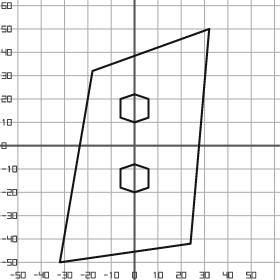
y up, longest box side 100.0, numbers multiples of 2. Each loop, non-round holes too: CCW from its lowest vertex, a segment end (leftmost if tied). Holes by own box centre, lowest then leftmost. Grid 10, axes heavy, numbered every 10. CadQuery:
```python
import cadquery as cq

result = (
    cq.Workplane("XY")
    .moveTo(-32.0, -50.0)
    .lineTo(24.0, -42.0)
    .lineTo(32.0, 50.0)
    .lineTo(-18.0, 32.0)
    .close()
    .moveTo(0.0, -20.0)
    .lineTo(6.0, -18.0)
    .lineTo(6.0, -10.0)
    .lineTo(0.0, -8.0)
    .lineTo(-6.0, -10.0)
    .lineTo(-6.0, -18.0)
    .close()
    .moveTo(0.0, 10.0)
    .lineTo(6.0, 12.0)
    .lineTo(6.0, 20.0)
    .lineTo(0.0, 22.0)
    .lineTo(-6.0, 20.0)
    .lineTo(-6.0, 12.0)
    .close()
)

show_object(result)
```